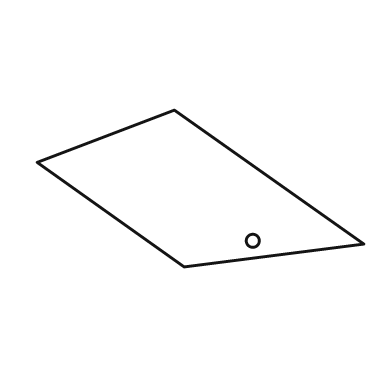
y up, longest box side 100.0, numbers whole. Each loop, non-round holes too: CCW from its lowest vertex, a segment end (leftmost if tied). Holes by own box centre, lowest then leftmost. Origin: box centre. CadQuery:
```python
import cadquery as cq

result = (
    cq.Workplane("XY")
    .moveTo(-5.0, -24.0)
    .lineTo(50.0, -17.0)
    .lineTo(-8.0, 24.0)
    .lineTo(-50.0, 8.0)
    .close()
    .moveTo(16.0, -16.0)
    .circle(2.0)
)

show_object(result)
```